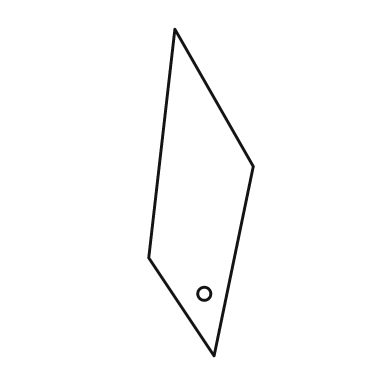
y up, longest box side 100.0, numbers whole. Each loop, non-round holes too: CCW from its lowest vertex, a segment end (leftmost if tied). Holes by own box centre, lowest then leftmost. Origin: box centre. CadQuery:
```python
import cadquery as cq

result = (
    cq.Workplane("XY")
    .moveTo(4.0, -50.0)
    .lineTo(16.0, 8.0)
    .lineTo(-8.0, 50.0)
    .lineTo(-16.0, -20.0)
    .close()
    .moveTo(1.0, -31.0)
    .circle(2.0)
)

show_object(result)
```